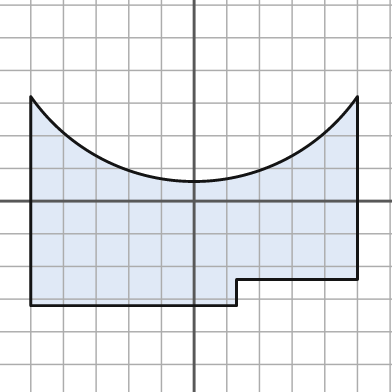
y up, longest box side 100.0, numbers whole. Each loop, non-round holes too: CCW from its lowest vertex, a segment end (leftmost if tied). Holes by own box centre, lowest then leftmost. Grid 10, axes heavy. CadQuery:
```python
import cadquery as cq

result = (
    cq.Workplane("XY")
    .moveTo(-50.0, -32.0)
    .lineTo(13.0, -32.0)
    .lineTo(13.0, -24.0)
    .lineTo(50.0, -24.0)
    .lineTo(50.0, 32.0)
    .threePointArc((0.0, 6.0), (-50.0, 32.0))
    .close()
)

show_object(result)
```